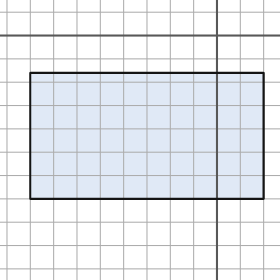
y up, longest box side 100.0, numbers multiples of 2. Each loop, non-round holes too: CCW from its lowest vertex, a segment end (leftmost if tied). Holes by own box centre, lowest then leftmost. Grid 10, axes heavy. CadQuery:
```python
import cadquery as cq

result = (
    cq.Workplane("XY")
    .moveTo(-80.0, -70.0)
    .lineTo(20.0, -70.0)
    .lineTo(20.0, -16.0)
    .lineTo(-80.0, -16.0)
    .close()
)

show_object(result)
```